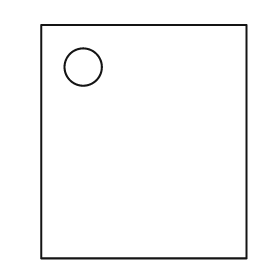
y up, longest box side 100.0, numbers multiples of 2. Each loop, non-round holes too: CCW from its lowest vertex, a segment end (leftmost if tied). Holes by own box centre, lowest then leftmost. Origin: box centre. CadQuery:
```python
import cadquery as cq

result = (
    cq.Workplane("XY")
    .moveTo(-44.0, -50.0)
    .lineTo(44.0, -50.0)
    .lineTo(44.0, 50.0)
    .lineTo(-44.0, 50.0)
    .close()
    .moveTo(-26.0, 32.0)
    .circle(8.0)
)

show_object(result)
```